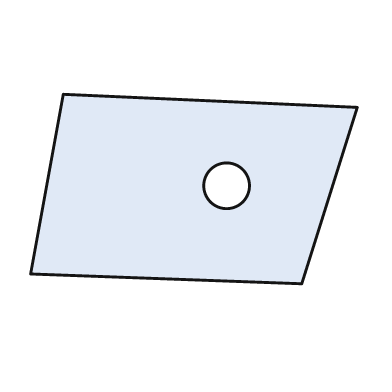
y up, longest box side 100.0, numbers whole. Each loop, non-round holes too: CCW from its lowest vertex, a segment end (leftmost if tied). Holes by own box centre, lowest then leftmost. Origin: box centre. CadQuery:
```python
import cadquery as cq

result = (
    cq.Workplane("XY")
    .moveTo(33.0, -29.0)
    .lineTo(50.0, 25.0)
    .lineTo(-40.0, 29.0)
    .lineTo(-50.0, -26.0)
    .close()
    .moveTo(10.0, 1.0)
    .circle(7.0)
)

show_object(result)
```